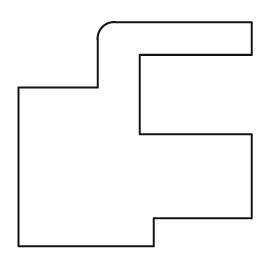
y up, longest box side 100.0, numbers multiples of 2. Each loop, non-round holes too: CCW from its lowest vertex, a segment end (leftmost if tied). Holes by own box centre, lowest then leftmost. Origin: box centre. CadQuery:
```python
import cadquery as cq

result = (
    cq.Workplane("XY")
    .moveTo(-50.0, -48.0)
    .lineTo(8.0, -48.0)
    .lineTo(8.0, -36.0)
    .lineTo(50.0, -36.0)
    .lineTo(50.0, 0.0)
    .lineTo(2.0, 0.0)
    .lineTo(2.0, 34.0)
    .lineTo(50.0, 34.0)
    .lineTo(50.0, 48.0)
    .lineTo(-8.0, 48.0)
    .threePointArc((-14.0, 46.0), (-16.0, 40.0))
    .lineTo(-16.0, 20.0)
    .lineTo(-50.0, 20.0)
    .close()
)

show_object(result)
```